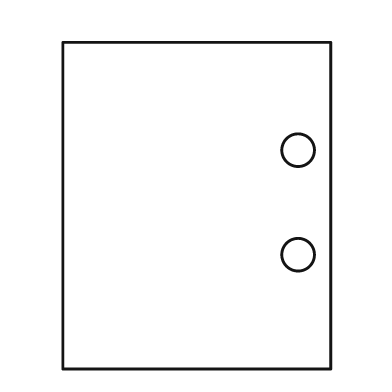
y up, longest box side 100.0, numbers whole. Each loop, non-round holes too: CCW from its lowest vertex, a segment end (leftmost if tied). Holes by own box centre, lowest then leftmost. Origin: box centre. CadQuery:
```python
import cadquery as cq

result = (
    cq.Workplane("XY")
    .moveTo(-41.0, -50.0)
    .lineTo(41.0, -50.0)
    .lineTo(41.0, 50.0)
    .lineTo(-41.0, 50.0)
    .close()
    .moveTo(31.0, -15.0)
    .circle(5.0)
    .moveTo(31.0, 17.0)
    .circle(5.0)
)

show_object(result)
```